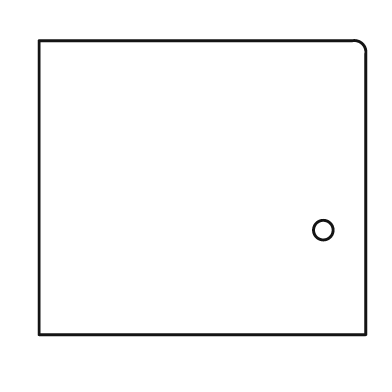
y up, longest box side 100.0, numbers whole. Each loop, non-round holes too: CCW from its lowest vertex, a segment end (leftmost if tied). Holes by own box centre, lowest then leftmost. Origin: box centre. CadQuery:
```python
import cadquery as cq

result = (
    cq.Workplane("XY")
    .moveTo(-50.0, -45.0)
    .lineTo(50.0, -45.0)
    .lineTo(50.0, 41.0)
    .threePointArc((49.0, 44.0), (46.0, 45.0))
    .lineTo(-50.0, 45.0)
    .close()
    .moveTo(37.0, -13.0)
    .circle(3.0)
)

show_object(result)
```